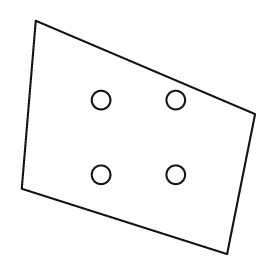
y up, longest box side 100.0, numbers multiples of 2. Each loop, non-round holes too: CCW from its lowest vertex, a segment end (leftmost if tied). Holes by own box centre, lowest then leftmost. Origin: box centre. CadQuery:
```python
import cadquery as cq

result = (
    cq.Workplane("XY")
    .moveTo(38.0, -50.0)
    .lineTo(50.0, 10.0)
    .lineTo(-44.0, 50.0)
    .lineTo(-50.0, -22.0)
    .close()
    .moveTo(-16.0, -16.0)
    .circle(4.0)
    .moveTo(16.0, -16.0)
    .circle(4.0)
    .moveTo(-16.0, 16.0)
    .circle(4.0)
    .moveTo(16.0, 16.0)
    .circle(4.0)
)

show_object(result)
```